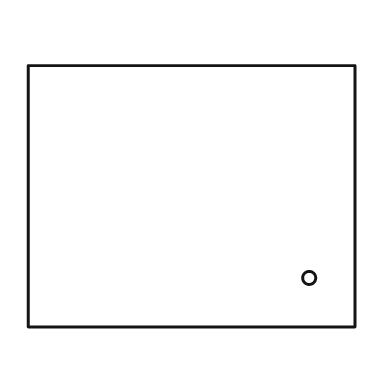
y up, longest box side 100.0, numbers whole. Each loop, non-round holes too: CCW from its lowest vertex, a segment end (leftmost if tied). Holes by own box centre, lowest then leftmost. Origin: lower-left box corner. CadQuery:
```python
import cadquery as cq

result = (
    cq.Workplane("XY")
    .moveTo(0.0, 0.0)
    .lineTo(100.0, 0.0)
    .lineTo(100.0, 80.0)
    .lineTo(0.0, 80.0)
    .close()
    .moveTo(86.0, 15.0)
    .circle(2.0)
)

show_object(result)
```